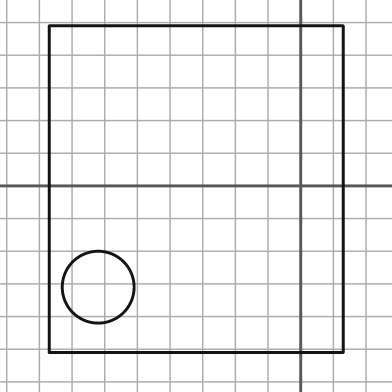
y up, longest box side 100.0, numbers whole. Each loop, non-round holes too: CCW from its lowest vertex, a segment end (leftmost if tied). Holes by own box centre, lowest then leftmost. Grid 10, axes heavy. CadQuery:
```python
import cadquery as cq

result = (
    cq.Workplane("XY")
    .moveTo(-77.0, -51.0)
    .lineTo(13.0, -51.0)
    .lineTo(13.0, 49.0)
    .lineTo(-77.0, 49.0)
    .close()
    .moveTo(-62.0, -31.0)
    .circle(11.0)
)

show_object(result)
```